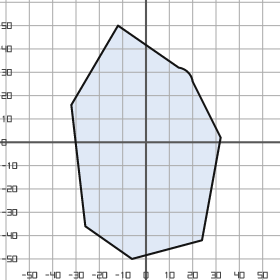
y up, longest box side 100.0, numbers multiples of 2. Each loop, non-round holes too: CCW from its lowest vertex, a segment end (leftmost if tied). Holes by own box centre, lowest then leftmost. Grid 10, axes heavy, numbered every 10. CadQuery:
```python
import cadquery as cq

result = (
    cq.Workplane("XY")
    .moveTo(-6.0, -50.0)
    .lineTo(24.0, -42.0)
    .lineTo(32.0, 2.0)
    .lineTo(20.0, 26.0)
    .threePointArc((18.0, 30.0), (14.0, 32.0))
    .lineTo(-12.0, 50.0)
    .lineTo(-32.0, 16.0)
    .lineTo(-26.0, -36.0)
    .close()
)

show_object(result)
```